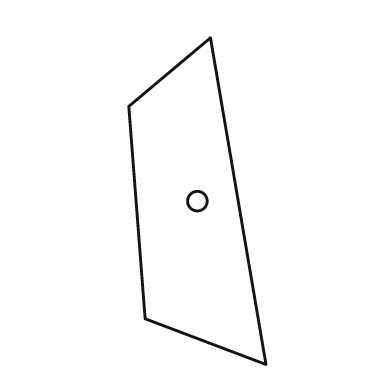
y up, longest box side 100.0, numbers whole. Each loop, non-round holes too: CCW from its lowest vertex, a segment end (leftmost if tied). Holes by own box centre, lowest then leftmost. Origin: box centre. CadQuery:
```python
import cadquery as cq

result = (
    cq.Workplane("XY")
    .moveTo(21.0, -50.0)
    .lineTo(4.0, 50.0)
    .lineTo(-21.0, 29.0)
    .lineTo(-16.0, -36.0)
    .close()
    .moveTo(0.0, 0.0)
    .circle(3.0)
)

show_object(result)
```